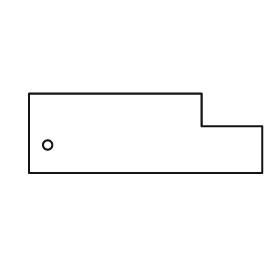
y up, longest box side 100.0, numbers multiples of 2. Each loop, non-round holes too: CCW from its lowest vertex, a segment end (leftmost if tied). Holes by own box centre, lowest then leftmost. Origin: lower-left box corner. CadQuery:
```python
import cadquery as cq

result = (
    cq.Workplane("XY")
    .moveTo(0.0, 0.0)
    .lineTo(100.0, 0.0)
    .lineTo(100.0, 20.0)
    .lineTo(74.0, 20.0)
    .lineTo(74.0, 34.0)
    .lineTo(0.0, 34.0)
    .close()
    .moveTo(8.0, 12.0)
    .circle(2.0)
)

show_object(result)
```